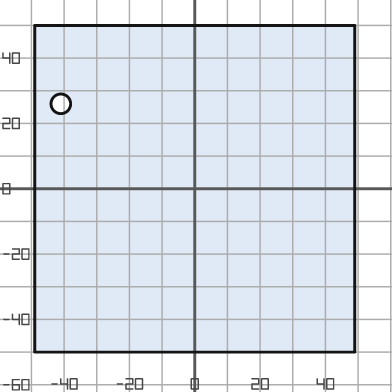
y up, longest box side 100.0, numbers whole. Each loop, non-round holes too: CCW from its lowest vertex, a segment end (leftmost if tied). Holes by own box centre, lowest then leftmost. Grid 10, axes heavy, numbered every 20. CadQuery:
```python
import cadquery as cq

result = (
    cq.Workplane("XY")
    .moveTo(-49.0, -50.0)
    .lineTo(49.0, -50.0)
    .lineTo(49.0, 50.0)
    .lineTo(-49.0, 50.0)
    .close()
    .moveTo(-41.0, 26.0)
    .circle(3.0)
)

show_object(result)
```